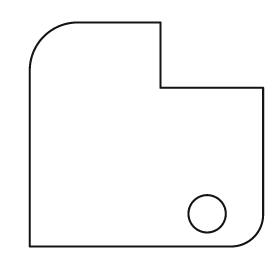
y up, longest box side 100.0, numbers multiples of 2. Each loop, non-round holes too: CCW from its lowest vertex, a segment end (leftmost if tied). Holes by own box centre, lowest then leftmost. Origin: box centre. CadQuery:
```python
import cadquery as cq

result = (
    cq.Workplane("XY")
    .moveTo(-50.0, -48.0)
    .lineTo(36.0, -48.0)
    .threePointArc((46.0, -44.0), (50.0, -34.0))
    .lineTo(50.0, 20.0)
    .lineTo(6.0, 20.0)
    .lineTo(6.0, 48.0)
    .lineTo(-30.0, 48.0)
    .threePointArc((-44.0, 42.0), (-50.0, 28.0))
    .close()
    .moveTo(26.0, -34.0)
    .circle(8.0)
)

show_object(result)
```